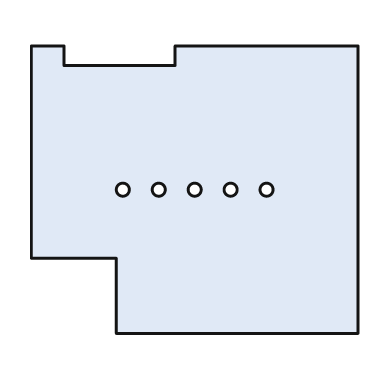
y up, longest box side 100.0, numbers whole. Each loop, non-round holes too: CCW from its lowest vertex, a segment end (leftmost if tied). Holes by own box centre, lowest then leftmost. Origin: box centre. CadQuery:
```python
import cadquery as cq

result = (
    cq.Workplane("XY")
    .moveTo(-24.0, -44.0)
    .lineTo(50.0, -44.0)
    .lineTo(50.0, 44.0)
    .lineTo(-6.0, 44.0)
    .lineTo(-6.0, 38.0)
    .lineTo(-40.0, 38.0)
    .lineTo(-40.0, 44.0)
    .lineTo(-50.0, 44.0)
    .lineTo(-50.0, -21.0)
    .lineTo(-24.0, -21.0)
    .close()
    .moveTo(-22.0, 0.0)
    .circle(2.0)
    .moveTo(-11.0, 0.0)
    .circle(2.0)
    .moveTo(0.0, 0.0)
    .circle(2.0)
    .moveTo(11.0, 0.0)
    .circle(2.0)
    .moveTo(22.0, 0.0)
    .circle(2.0)
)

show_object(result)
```